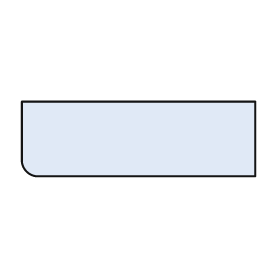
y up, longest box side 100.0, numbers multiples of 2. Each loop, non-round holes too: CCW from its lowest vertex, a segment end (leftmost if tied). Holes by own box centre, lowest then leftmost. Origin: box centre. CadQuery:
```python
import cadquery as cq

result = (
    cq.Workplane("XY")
    .moveTo(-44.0, -16.0)
    .lineTo(50.0, -16.0)
    .lineTo(50.0, 16.0)
    .lineTo(-50.0, 16.0)
    .lineTo(-50.0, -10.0)
    .threePointArc((-48.0, -14.0), (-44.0, -16.0))
    .close()
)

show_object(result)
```